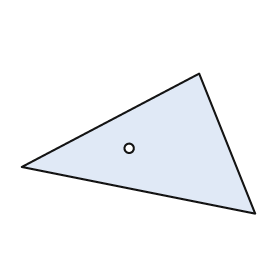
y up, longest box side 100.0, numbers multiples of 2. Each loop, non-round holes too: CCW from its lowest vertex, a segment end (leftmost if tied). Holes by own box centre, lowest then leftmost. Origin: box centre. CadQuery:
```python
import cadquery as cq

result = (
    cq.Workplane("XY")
    .moveTo(50.0, -30.0)
    .lineTo(26.0, 30.0)
    .lineTo(-50.0, -10.0)
    .close()
    .moveTo(-4.0, -2.0)
    .circle(2.0)
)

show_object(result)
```